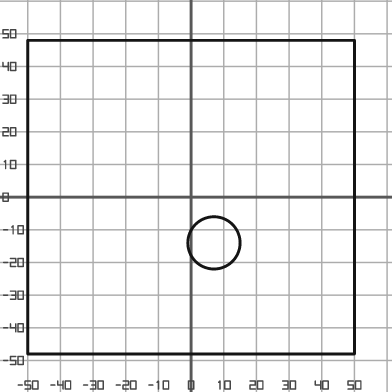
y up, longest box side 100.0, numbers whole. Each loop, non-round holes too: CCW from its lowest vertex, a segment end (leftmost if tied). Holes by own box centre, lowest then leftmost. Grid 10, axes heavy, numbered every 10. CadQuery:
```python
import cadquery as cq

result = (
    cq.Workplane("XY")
    .moveTo(-50.0, -48.0)
    .lineTo(50.0, -48.0)
    .lineTo(50.0, 48.0)
    .lineTo(-50.0, 48.0)
    .close()
    .moveTo(7.0, -14.0)
    .circle(8.0)
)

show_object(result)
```